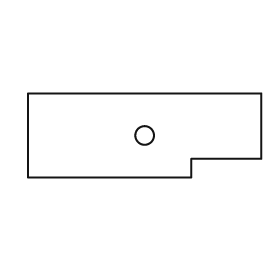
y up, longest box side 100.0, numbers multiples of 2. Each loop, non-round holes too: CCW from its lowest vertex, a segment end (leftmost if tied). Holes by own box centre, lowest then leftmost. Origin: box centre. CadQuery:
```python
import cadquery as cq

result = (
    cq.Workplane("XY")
    .moveTo(-50.0, -18.0)
    .lineTo(20.0, -18.0)
    .lineTo(20.0, -10.0)
    .lineTo(50.0, -10.0)
    .lineTo(50.0, 18.0)
    .lineTo(-50.0, 18.0)
    .close()
    .moveTo(0.0, 0.0)
    .circle(4.0)
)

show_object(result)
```